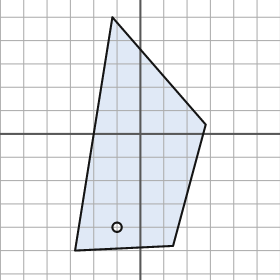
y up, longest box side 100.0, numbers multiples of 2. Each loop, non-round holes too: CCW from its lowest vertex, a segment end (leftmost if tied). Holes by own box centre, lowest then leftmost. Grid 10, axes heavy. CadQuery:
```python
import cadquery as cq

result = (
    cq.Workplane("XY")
    .moveTo(-28.0, -50.0)
    .lineTo(14.0, -48.0)
    .lineTo(28.0, 4.0)
    .lineTo(-12.0, 50.0)
    .close()
    .moveTo(-10.0, -40.0)
    .circle(2.0)
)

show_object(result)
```